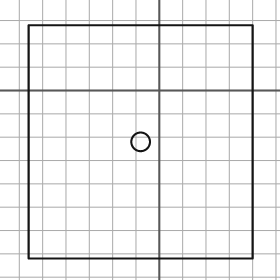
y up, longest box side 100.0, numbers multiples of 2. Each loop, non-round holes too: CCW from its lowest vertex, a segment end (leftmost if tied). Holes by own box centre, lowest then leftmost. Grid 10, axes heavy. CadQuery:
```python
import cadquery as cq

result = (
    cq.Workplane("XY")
    .moveTo(-56.0, -72.0)
    .lineTo(40.0, -72.0)
    .lineTo(40.0, 28.0)
    .lineTo(-56.0, 28.0)
    .close()
    .moveTo(-8.0, -22.0)
    .circle(4.0)
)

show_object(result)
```